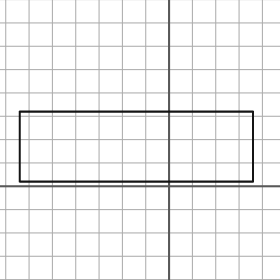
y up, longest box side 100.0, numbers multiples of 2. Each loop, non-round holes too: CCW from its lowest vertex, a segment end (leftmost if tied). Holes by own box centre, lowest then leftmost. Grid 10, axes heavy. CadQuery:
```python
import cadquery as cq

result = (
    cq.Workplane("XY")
    .moveTo(-64.0, 2.0)
    .lineTo(36.0, 2.0)
    .lineTo(36.0, 32.0)
    .lineTo(-64.0, 32.0)
    .close()
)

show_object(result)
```